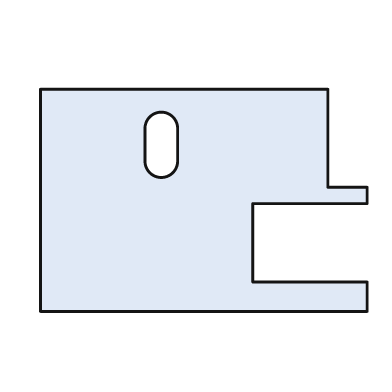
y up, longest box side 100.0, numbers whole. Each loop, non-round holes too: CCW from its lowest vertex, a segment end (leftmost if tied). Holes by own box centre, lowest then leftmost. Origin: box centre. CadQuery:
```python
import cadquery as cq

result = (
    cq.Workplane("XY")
    .moveTo(-50.0, -34.0)
    .lineTo(50.0, -34.0)
    .lineTo(50.0, -25.0)
    .lineTo(15.0, -25.0)
    .lineTo(15.0, -1.0)
    .lineTo(50.0, -1.0)
    .lineTo(50.0, 4.0)
    .lineTo(38.0, 4.0)
    .lineTo(38.0, 34.0)
    .lineTo(-50.0, 34.0)
    .close()
    .moveTo(-18.0, 12.0)
    .threePointArc((-13.0, 7.0), (-8.0, 12.0))
    .lineTo(-8.0, 22.0)
    .threePointArc((-13.0, 27.0), (-18.0, 22.0))
    .close()
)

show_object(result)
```